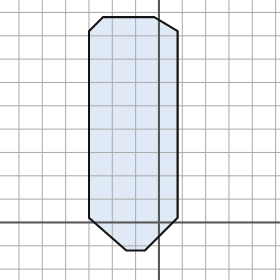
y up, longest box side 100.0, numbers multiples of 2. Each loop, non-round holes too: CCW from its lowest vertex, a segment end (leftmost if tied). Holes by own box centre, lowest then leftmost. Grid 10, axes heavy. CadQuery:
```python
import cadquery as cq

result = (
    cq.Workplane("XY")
    .moveTo(-14.0, -12.0)
    .lineTo(-6.0, -12.0)
    .lineTo(8.0, 2.0)
    .lineTo(8.0, 82.0)
    .lineTo(-2.0, 88.0)
    .lineTo(-24.0, 88.0)
    .lineTo(-30.0, 82.0)
    .lineTo(-30.0, 2.0)
    .close()
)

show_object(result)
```